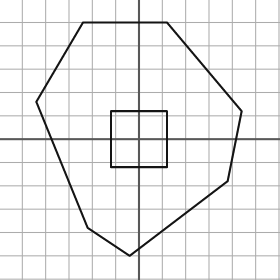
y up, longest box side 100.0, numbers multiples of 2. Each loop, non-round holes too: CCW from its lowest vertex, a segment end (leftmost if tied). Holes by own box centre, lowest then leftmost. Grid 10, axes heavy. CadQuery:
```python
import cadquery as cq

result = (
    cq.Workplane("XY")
    .moveTo(-4.0, -50.0)
    .lineTo(38.0, -18.0)
    .lineTo(44.0, 12.0)
    .lineTo(12.0, 50.0)
    .lineTo(-24.0, 50.0)
    .lineTo(-44.0, 16.0)
    .lineTo(-22.0, -38.0)
    .close()
    .moveTo(-12.0, -12.0)
    .lineTo(12.0, -12.0)
    .lineTo(12.0, 12.0)
    .lineTo(-12.0, 12.0)
    .close()
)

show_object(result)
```